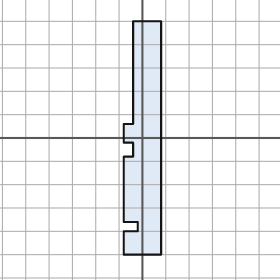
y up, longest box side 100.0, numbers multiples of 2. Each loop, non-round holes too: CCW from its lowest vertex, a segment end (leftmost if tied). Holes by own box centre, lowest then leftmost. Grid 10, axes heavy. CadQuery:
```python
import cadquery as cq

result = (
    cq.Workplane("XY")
    .moveTo(-8.0, -50.0)
    .lineTo(8.0, -50.0)
    .lineTo(8.0, 50.0)
    .lineTo(-4.0, 50.0)
    .lineTo(-4.0, 6.0)
    .lineTo(-8.0, 6.0)
    .lineTo(-8.0, -2.0)
    .lineTo(-4.0, -2.0)
    .lineTo(-4.0, -8.0)
    .lineTo(-8.0, -8.0)
    .lineTo(-8.0, -36.0)
    .lineTo(-2.0, -36.0)
    .lineTo(-2.0, -40.0)
    .lineTo(-8.0, -40.0)
    .close()
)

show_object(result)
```